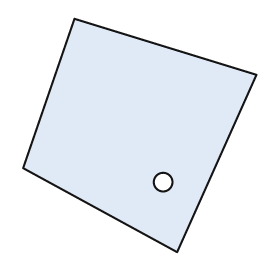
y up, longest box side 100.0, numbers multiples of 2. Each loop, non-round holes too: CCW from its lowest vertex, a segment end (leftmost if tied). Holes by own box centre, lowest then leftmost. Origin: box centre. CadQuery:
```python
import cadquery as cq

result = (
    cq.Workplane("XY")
    .moveTo(16.0, -50.0)
    .lineTo(50.0, 26.0)
    .lineTo(-28.0, 50.0)
    .lineTo(-50.0, -14.0)
    .close()
    .moveTo(10.0, -20.0)
    .circle(4.0)
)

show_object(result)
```